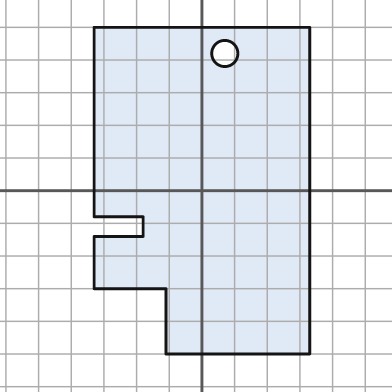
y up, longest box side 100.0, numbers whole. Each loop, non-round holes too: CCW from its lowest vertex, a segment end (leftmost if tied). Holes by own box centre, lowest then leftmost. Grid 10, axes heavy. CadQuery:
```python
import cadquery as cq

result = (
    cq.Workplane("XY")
    .moveTo(-11.0, -50.0)
    .lineTo(33.0, -50.0)
    .lineTo(33.0, 50.0)
    .lineTo(-33.0, 50.0)
    .lineTo(-33.0, -8.0)
    .lineTo(-18.0, -8.0)
    .lineTo(-18.0, -14.0)
    .lineTo(-33.0, -14.0)
    .lineTo(-33.0, -30.0)
    .lineTo(-11.0, -30.0)
    .close()
    .moveTo(7.0, 42.0)
    .circle(4.0)
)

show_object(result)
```